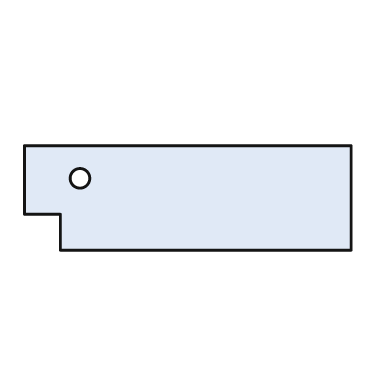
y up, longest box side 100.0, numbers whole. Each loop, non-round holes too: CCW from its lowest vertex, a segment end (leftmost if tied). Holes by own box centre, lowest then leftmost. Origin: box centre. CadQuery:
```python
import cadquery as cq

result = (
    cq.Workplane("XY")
    .moveTo(-39.0, -16.0)
    .lineTo(50.0, -16.0)
    .lineTo(50.0, 16.0)
    .lineTo(-50.0, 16.0)
    .lineTo(-50.0, -5.0)
    .lineTo(-39.0, -5.0)
    .close()
    .moveTo(-33.0, 6.0)
    .circle(3.0)
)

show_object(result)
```